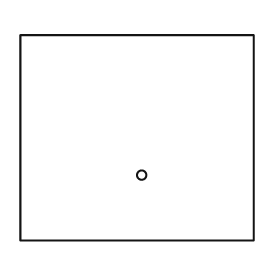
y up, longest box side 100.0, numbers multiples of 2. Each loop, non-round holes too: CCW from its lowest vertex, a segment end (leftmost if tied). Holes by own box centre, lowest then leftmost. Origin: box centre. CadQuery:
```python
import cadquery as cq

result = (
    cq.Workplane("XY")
    .moveTo(-50.0, -44.0)
    .lineTo(50.0, -44.0)
    .lineTo(50.0, 44.0)
    .lineTo(-50.0, 44.0)
    .close()
    .moveTo(2.0, -16.0)
    .circle(2.0)
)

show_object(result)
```